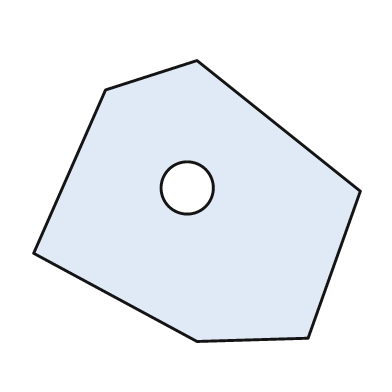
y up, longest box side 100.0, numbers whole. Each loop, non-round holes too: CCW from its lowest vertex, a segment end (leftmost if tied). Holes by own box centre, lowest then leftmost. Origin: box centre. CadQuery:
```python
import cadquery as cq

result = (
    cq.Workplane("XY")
    .moveTo(0.0, -43.0)
    .lineTo(34.0, -42.0)
    .lineTo(50.0, 3.0)
    .lineTo(0.0, 43.0)
    .lineTo(-28.0, 34.0)
    .lineTo(-50.0, -16.0)
    .close()
    .moveTo(-3.0, 4.0)
    .circle(8.0)
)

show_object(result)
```